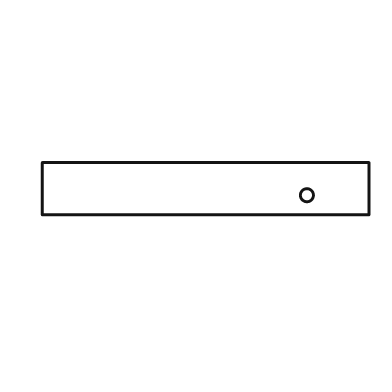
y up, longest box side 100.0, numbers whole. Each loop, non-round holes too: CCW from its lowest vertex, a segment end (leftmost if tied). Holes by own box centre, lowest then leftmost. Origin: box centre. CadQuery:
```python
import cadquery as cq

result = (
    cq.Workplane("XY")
    .moveTo(-50.0, -8.0)
    .lineTo(50.0, -8.0)
    .lineTo(50.0, 8.0)
    .lineTo(-50.0, 8.0)
    .close()
    .moveTo(31.0, -2.0)
    .circle(2.0)
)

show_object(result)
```